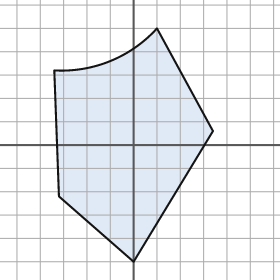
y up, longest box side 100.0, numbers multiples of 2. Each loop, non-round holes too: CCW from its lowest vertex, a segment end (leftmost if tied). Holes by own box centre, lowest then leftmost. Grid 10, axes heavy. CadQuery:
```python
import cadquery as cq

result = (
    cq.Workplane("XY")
    .moveTo(0.0, -50.0)
    .lineTo(34.0, 6.0)
    .lineTo(10.0, 50.0)
    .threePointArc((-10.0, 36.0), (-34.0, 32.0))
    .lineTo(-32.0, -22.0)
    .close()
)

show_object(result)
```